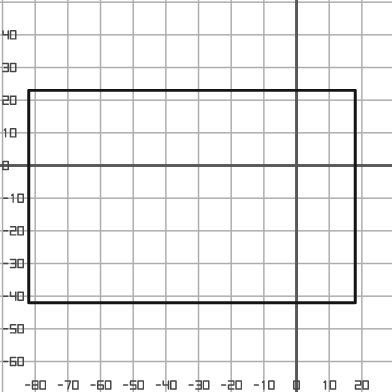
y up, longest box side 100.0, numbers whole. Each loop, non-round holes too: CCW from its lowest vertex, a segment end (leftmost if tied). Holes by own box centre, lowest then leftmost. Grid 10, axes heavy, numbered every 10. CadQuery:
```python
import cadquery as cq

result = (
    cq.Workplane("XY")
    .moveTo(-82.0, -42.0)
    .lineTo(18.0, -42.0)
    .lineTo(18.0, 23.0)
    .lineTo(-82.0, 23.0)
    .close()
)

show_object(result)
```